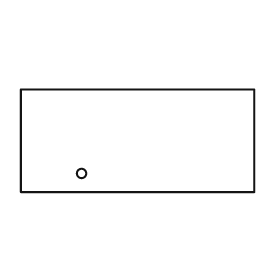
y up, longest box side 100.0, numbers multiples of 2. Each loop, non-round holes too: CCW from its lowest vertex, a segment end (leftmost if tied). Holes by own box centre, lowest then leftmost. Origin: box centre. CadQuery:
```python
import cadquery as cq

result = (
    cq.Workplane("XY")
    .moveTo(-50.0, -22.0)
    .lineTo(50.0, -22.0)
    .lineTo(50.0, 22.0)
    .lineTo(-50.0, 22.0)
    .close()
    .moveTo(-24.0, -14.0)
    .circle(2.0)
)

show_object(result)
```